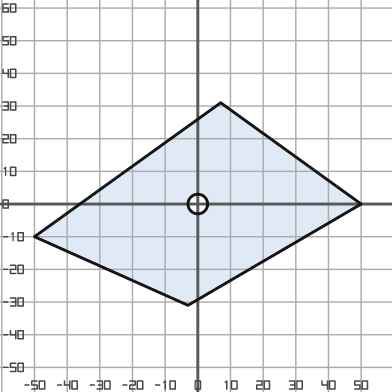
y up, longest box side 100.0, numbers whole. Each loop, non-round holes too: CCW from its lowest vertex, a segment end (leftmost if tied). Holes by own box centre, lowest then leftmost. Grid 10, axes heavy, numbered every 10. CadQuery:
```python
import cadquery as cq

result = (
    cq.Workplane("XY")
    .moveTo(-3.0, -31.0)
    .lineTo(50.0, 0.0)
    .lineTo(7.0, 31.0)
    .lineTo(-50.0, -10.0)
    .close()
    .moveTo(0.0, 0.0)
    .circle(3.0)
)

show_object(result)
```